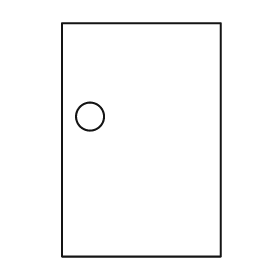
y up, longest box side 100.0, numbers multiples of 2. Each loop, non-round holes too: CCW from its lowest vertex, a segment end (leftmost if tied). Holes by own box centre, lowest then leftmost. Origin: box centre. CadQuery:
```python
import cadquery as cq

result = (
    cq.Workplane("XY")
    .moveTo(-34.0, -50.0)
    .lineTo(34.0, -50.0)
    .lineTo(34.0, 50.0)
    .lineTo(-34.0, 50.0)
    .close()
    .moveTo(-22.0, 10.0)
    .circle(6.0)
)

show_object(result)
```